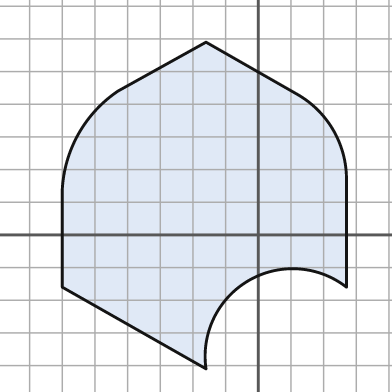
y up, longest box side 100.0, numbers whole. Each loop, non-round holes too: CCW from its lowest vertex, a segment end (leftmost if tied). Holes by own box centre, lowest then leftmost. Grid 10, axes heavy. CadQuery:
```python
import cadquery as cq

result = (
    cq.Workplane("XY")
    .moveTo(-16.0, -41.0)
    .threePointArc((-3.0, -14.0), (27.0, -16.0))
    .lineTo(27.0, 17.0)
    .threePointArc((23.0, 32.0), (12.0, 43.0))
    .lineTo(-16.0, 59.0)
    .lineTo(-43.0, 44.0)
    .threePointArc((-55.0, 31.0), (-60.0, 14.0))
    .lineTo(-60.0, -16.0)
    .close()
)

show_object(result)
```